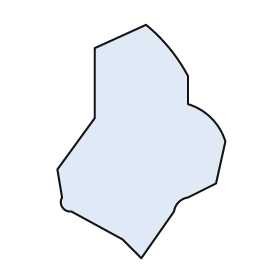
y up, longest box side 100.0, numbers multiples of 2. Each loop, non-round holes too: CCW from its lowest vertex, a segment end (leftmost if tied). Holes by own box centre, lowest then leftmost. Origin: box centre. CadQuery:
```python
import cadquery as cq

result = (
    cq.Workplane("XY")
    .moveTo(0.0, -50.0)
    .lineTo(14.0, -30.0)
    .threePointArc((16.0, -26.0), (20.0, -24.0))
    .lineTo(32.0, -18.0)
    .lineTo(36.0, 0.0)
    .threePointArc((30.0, 10.0), (20.0, 16.0))
    .lineTo(20.0, 28.0)
    .threePointArc((12.0, 40.0), (2.0, 50.0))
    .lineTo(-20.0, 40.0)
    .lineTo(-20.0, 10.0)
    .lineTo(-36.0, -12.0)
    .lineTo(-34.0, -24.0)
    .threePointArc((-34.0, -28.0), (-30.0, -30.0))
    .lineTo(-8.0, -42.0)
    .close()
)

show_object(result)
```